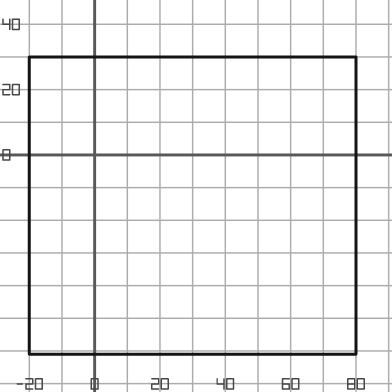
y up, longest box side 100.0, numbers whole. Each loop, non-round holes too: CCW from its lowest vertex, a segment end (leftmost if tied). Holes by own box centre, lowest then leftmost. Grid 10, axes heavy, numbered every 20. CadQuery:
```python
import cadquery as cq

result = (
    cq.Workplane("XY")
    .moveTo(-20.0, -61.0)
    .lineTo(80.0, -61.0)
    .lineTo(80.0, 30.0)
    .lineTo(-20.0, 30.0)
    .close()
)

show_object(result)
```